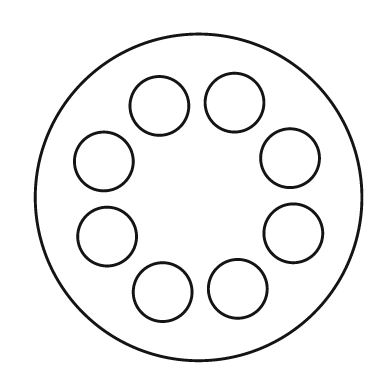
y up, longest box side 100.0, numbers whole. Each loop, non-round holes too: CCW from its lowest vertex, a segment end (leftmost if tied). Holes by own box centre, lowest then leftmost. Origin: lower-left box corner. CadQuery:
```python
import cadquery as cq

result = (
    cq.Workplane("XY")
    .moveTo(50.0, 50.0)
    .circle(50.0)
    .moveTo(39.0, 21.0)
    .circle(9.0)
    .moveTo(62.0, 22.0)
    .circle(9.0)
    .moveTo(22.0, 38.0)
    .circle(9.0)
    .moveTo(79.0, 39.0)
    .circle(9.0)
    .moveTo(21.0, 61.0)
    .circle(9.0)
    .moveTo(78.0, 62.0)
    .circle(9.0)
    .moveTo(38.0, 78.0)
    .circle(9.0)
    .moveTo(61.0, 79.0)
    .circle(9.0)
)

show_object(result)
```